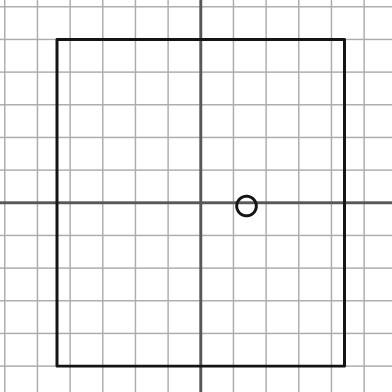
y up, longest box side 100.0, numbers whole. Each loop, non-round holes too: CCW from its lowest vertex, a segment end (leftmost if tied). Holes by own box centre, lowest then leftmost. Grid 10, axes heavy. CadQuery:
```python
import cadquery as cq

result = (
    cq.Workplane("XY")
    .moveTo(-44.0, -50.0)
    .lineTo(44.0, -50.0)
    .lineTo(44.0, 50.0)
    .lineTo(-44.0, 50.0)
    .close()
    .moveTo(14.0, -1.0)
    .circle(3.0)
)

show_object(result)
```